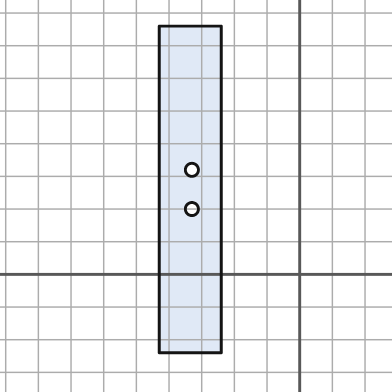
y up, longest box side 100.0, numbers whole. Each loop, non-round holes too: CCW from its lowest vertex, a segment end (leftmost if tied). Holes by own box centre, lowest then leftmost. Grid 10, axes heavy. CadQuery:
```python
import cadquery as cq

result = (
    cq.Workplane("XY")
    .moveTo(-43.0, -24.0)
    .lineTo(-24.0, -24.0)
    .lineTo(-24.0, 76.0)
    .lineTo(-43.0, 76.0)
    .close()
    .moveTo(-33.0, 20.0)
    .circle(2.0)
    .moveTo(-33.0, 32.0)
    .circle(2.0)
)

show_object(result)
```